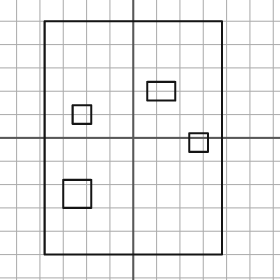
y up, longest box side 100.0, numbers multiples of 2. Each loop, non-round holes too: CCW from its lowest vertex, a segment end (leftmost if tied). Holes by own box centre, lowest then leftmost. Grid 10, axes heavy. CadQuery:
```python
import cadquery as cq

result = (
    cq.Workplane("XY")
    .moveTo(-38.0, -50.0)
    .lineTo(38.0, -50.0)
    .lineTo(38.0, 50.0)
    .lineTo(-38.0, 50.0)
    .close()
    .moveTo(-30.0, -30.0)
    .lineTo(-18.0, -30.0)
    .lineTo(-18.0, -18.0)
    .lineTo(-30.0, -18.0)
    .close()
    .moveTo(24.0, -6.0)
    .lineTo(32.0, -6.0)
    .lineTo(32.0, 2.0)
    .lineTo(24.0, 2.0)
    .close()
    .moveTo(-26.0, 6.0)
    .lineTo(-18.0, 6.0)
    .lineTo(-18.0, 14.0)
    .lineTo(-26.0, 14.0)
    .close()
    .moveTo(6.0, 16.0)
    .lineTo(18.0, 16.0)
    .lineTo(18.0, 24.0)
    .lineTo(6.0, 24.0)
    .close()
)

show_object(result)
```